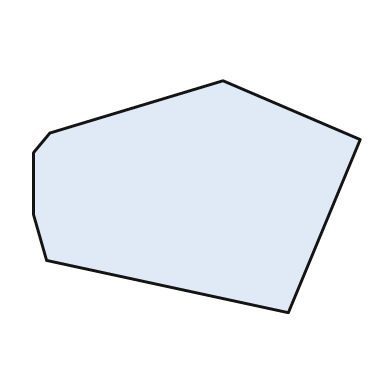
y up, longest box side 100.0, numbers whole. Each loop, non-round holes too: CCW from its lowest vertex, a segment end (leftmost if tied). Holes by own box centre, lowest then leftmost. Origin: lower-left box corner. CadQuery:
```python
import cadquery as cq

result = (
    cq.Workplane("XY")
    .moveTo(78.0, 0.0)
    .lineTo(100.0, 53.0)
    .lineTo(58.0, 71.0)
    .lineTo(5.0, 55.0)
    .lineTo(0.0, 49.0)
    .lineTo(0.0, 30.0)
    .lineTo(4.0, 16.0)
    .close()
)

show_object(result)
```